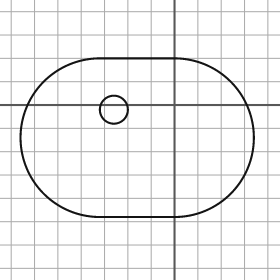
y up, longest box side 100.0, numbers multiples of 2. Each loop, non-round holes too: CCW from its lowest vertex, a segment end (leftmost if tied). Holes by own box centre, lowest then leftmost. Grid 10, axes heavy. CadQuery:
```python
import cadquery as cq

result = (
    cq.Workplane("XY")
    .moveTo(-32.0, -48.0)
    .lineTo(0.0, -48.0)
    .threePointArc((34.0, -14.0), (0.0, 20.0))
    .lineTo(-32.0, 20.0)
    .threePointArc((-66.0, -14.0), (-32.0, -48.0))
    .close()
    .moveTo(-26.0, -2.0)
    .circle(6.0)
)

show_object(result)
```